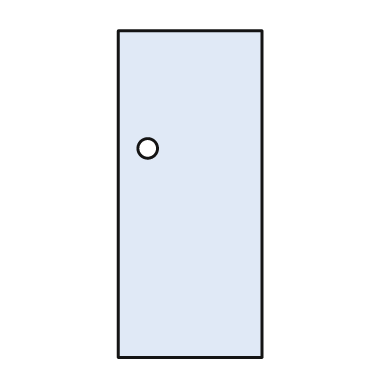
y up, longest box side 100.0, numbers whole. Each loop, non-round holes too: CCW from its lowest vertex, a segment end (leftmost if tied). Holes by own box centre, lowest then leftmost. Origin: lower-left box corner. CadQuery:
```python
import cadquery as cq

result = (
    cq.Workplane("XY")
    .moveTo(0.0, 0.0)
    .lineTo(44.0, 0.0)
    .lineTo(44.0, 100.0)
    .lineTo(0.0, 100.0)
    .close()
    .moveTo(9.0, 64.0)
    .circle(3.0)
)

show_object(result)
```